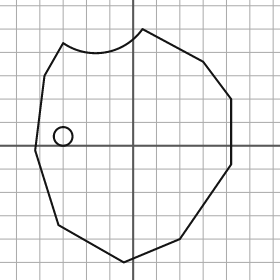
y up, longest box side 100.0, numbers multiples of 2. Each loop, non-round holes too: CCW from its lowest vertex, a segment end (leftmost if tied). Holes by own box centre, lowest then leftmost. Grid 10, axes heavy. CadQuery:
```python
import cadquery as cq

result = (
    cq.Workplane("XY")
    .moveTo(-4.0, -50.0)
    .lineTo(20.0, -40.0)
    .lineTo(42.0, -8.0)
    .lineTo(42.0, 20.0)
    .lineTo(30.0, 36.0)
    .lineTo(4.0, 50.0)
    .threePointArc((-12.0, 40.0), (-30.0, 44.0))
    .lineTo(-38.0, 30.0)
    .lineTo(-42.0, -2.0)
    .lineTo(-32.0, -34.0)
    .close()
    .moveTo(-30.0, 4.0)
    .circle(4.0)
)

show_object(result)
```